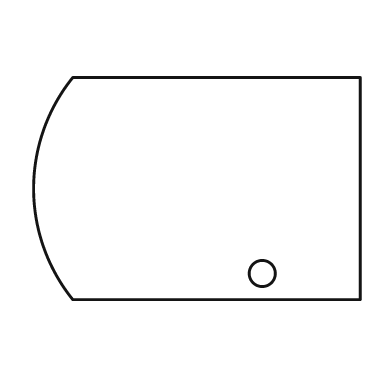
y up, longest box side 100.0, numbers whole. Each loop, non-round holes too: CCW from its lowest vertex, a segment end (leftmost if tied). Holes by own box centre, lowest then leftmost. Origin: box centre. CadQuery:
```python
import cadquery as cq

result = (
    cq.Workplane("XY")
    .moveTo(-38.0, -34.0)
    .lineTo(50.0, -34.0)
    .lineTo(50.0, 34.0)
    .lineTo(-38.0, 34.0)
    .threePointArc((-50.0, 0.0), (-38.0, -34.0))
    .close()
    .moveTo(20.0, -26.0)
    .circle(4.0)
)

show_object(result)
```